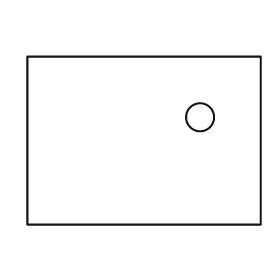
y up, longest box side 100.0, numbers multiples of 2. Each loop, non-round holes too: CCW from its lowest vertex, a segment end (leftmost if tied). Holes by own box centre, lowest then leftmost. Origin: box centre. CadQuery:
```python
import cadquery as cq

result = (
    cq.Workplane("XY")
    .moveTo(-50.0, -36.0)
    .lineTo(50.0, -36.0)
    .lineTo(50.0, 36.0)
    .lineTo(-50.0, 36.0)
    .close()
    .moveTo(24.0, 10.0)
    .circle(6.0)
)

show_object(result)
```